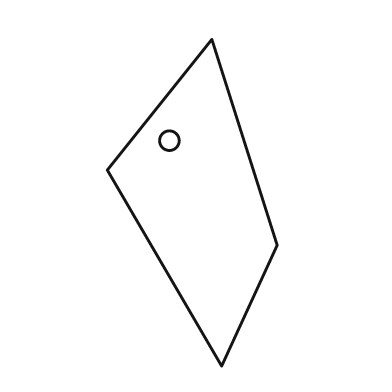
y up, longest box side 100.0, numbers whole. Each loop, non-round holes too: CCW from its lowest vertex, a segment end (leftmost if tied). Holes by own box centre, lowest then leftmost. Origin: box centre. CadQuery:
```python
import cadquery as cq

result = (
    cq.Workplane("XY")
    .moveTo(9.0, -50.0)
    .lineTo(26.0, -13.0)
    .lineTo(6.0, 50.0)
    .lineTo(-26.0, 10.0)
    .close()
    .moveTo(-7.0, 19.0)
    .circle(3.0)
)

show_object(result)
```